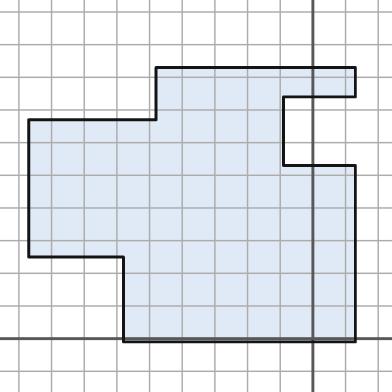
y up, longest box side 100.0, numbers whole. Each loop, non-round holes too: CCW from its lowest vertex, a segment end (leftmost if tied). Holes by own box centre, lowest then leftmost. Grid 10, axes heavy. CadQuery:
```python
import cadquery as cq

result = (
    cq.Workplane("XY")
    .moveTo(-58.0, -1.0)
    .lineTo(13.0, -1.0)
    .lineTo(13.0, 53.0)
    .lineTo(-9.0, 53.0)
    .lineTo(-9.0, 74.0)
    .lineTo(13.0, 74.0)
    .lineTo(13.0, 83.0)
    .lineTo(-48.0, 83.0)
    .lineTo(-48.0, 67.0)
    .lineTo(-87.0, 67.0)
    .lineTo(-87.0, 25.0)
    .lineTo(-58.0, 25.0)
    .close()
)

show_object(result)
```